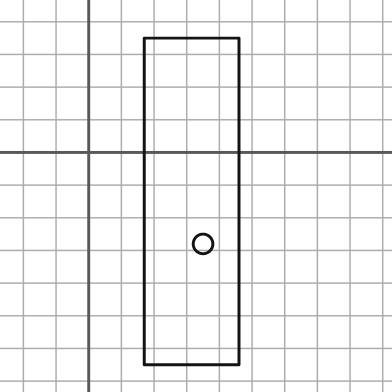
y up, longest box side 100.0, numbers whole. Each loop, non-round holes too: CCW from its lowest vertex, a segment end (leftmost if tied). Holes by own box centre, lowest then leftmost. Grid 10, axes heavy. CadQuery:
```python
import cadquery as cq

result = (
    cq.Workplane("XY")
    .moveTo(17.0, -65.0)
    .lineTo(46.0, -65.0)
    .lineTo(46.0, 35.0)
    .lineTo(17.0, 35.0)
    .close()
    .moveTo(35.0, -28.0)
    .circle(3.0)
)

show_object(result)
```